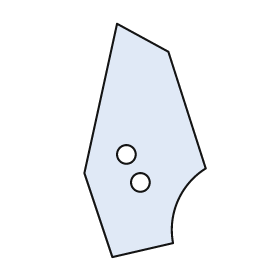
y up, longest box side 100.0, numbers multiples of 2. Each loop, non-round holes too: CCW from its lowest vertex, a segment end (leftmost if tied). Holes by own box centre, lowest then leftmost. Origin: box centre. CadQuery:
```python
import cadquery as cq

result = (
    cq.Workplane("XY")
    .moveTo(-14.0, -50.0)
    .lineTo(12.0, -44.0)
    .threePointArc((14.0, -26.0), (26.0, -12.0))
    .lineTo(10.0, 38.0)
    .lineTo(-12.0, 50.0)
    .lineTo(-26.0, -14.0)
    .close()
    .moveTo(-2.0, -18.0)
    .circle(4.0)
    .moveTo(-8.0, -6.0)
    .circle(4.0)
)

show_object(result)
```